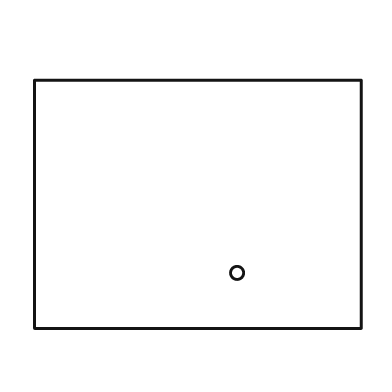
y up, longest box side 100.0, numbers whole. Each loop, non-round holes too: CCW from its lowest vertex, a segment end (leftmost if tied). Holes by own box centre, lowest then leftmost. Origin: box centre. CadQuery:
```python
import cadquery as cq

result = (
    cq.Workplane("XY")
    .moveTo(-50.0, -38.0)
    .lineTo(50.0, -38.0)
    .lineTo(50.0, 38.0)
    .lineTo(-50.0, 38.0)
    .close()
    .moveTo(12.0, -21.0)
    .circle(2.0)
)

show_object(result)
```